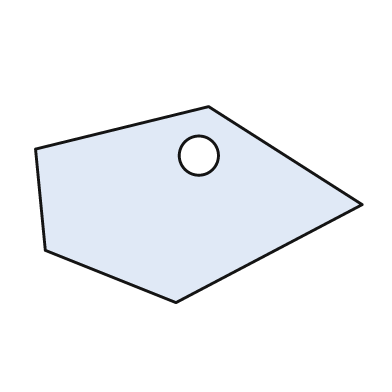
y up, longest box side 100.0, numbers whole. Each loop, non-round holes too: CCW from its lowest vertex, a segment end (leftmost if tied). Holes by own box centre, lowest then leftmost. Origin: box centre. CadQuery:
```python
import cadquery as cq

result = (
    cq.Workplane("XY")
    .moveTo(-7.0, -30.0)
    .lineTo(50.0, 0.0)
    .lineTo(3.0, 30.0)
    .lineTo(-50.0, 17.0)
    .lineTo(-47.0, -14.0)
    .close()
    .moveTo(0.0, 15.0)
    .circle(6.0)
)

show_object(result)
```